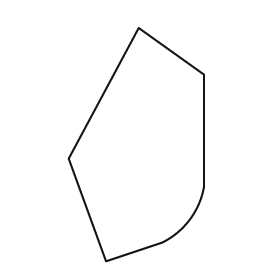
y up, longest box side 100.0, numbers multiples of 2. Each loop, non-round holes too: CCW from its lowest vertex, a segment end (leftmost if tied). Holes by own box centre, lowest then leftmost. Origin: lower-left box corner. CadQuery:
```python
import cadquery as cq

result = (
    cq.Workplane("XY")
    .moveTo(16.0, 0.0)
    .lineTo(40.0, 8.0)
    .threePointArc((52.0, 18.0), (58.0, 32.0))
    .lineTo(58.0, 80.0)
    .lineTo(30.0, 100.0)
    .lineTo(0.0, 44.0)
    .close()
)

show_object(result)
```